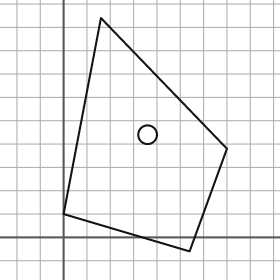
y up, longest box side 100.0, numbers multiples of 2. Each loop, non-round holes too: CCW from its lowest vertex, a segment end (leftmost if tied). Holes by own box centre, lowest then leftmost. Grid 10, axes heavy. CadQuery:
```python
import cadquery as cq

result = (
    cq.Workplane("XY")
    .moveTo(54.0, -6.0)
    .lineTo(70.0, 38.0)
    .lineTo(16.0, 94.0)
    .lineTo(0.0, 10.0)
    .close()
    .moveTo(36.0, 44.0)
    .circle(4.0)
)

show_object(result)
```